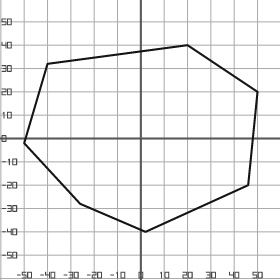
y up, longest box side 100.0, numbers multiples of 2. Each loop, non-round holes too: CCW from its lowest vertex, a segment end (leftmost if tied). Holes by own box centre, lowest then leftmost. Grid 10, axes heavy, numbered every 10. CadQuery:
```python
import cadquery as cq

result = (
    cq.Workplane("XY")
    .moveTo(2.0, -40.0)
    .lineTo(46.0, -20.0)
    .lineTo(50.0, 20.0)
    .lineTo(20.0, 40.0)
    .lineTo(-40.0, 32.0)
    .lineTo(-50.0, -2.0)
    .lineTo(-26.0, -28.0)
    .close()
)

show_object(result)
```